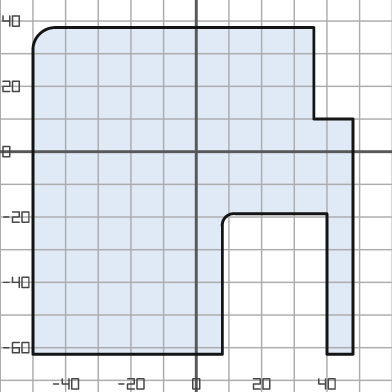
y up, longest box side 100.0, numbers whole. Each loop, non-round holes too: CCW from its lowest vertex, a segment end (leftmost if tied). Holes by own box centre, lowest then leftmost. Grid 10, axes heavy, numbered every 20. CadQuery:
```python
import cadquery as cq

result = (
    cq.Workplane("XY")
    .moveTo(-50.0, -62.0)
    .lineTo(8.0, -62.0)
    .lineTo(8.0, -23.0)
    .threePointArc((9.0, -20.0), (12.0, -19.0))
    .lineTo(40.0, -19.0)
    .lineTo(40.0, -62.0)
    .lineTo(48.0, -62.0)
    .lineTo(48.0, 10.0)
    .lineTo(36.0, 10.0)
    .lineTo(36.0, 38.0)
    .lineTo(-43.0, 38.0)
    .threePointArc((-48.0, 36.0), (-50.0, 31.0))
    .close()
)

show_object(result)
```